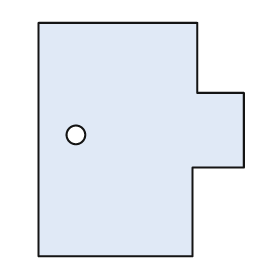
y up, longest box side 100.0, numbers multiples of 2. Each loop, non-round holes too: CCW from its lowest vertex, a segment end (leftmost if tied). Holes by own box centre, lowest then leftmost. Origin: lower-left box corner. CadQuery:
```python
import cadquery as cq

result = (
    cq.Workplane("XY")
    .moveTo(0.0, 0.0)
    .lineTo(66.0, 0.0)
    .lineTo(66.0, 38.0)
    .lineTo(88.0, 38.0)
    .lineTo(88.0, 70.0)
    .lineTo(68.0, 70.0)
    .lineTo(68.0, 100.0)
    .lineTo(0.0, 100.0)
    .close()
    .moveTo(16.0, 52.0)
    .circle(4.0)
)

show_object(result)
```